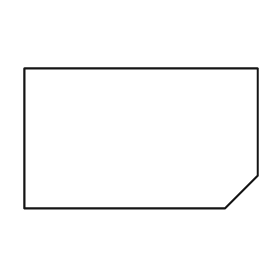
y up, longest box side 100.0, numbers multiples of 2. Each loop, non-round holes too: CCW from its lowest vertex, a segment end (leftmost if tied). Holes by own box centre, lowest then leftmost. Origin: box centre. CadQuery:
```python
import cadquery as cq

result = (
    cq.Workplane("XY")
    .moveTo(-50.0, -30.0)
    .lineTo(36.0, -30.0)
    .lineTo(50.0, -16.0)
    .lineTo(50.0, 30.0)
    .lineTo(-50.0, 30.0)
    .close()
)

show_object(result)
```